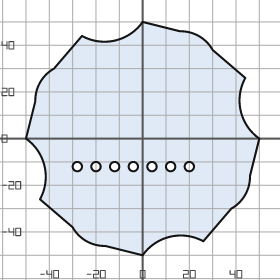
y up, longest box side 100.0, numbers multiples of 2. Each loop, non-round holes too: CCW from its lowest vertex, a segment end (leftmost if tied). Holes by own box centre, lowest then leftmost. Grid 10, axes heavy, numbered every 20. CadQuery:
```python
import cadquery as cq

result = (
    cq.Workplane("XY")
    .moveTo(0.0, -50.0)
    .threePointArc((12.0, -42.0), (26.0, -44.0))
    .lineTo(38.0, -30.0)
    .threePointArc((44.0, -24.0), (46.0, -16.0))
    .lineTo(50.0, 0.0)
    .threePointArc((42.0, 12.0), (44.0, 26.0))
    .lineTo(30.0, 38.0)
    .threePointArc((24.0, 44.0), (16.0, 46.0))
    .lineTo(0.0, 50.0)
    .threePointArc((-12.0, 42.0), (-26.0, 44.0))
    .lineTo(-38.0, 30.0)
    .threePointArc((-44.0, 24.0), (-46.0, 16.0))
    .lineTo(-50.0, 0.0)
    .threePointArc((-42.0, -12.0), (-44.0, -26.0))
    .lineTo(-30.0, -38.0)
    .threePointArc((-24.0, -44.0), (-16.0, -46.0))
    .close()
    .moveTo(-28.0, -12.0)
    .circle(2.0)
    .moveTo(-20.0, -12.0)
    .circle(2.0)
    .moveTo(-12.0, -12.0)
    .circle(2.0)
    .moveTo(-4.0, -12.0)
    .circle(2.0)
    .moveTo(4.0, -12.0)
    .circle(2.0)
    .moveTo(12.0, -12.0)
    .circle(2.0)
    .moveTo(20.0, -12.0)
    .circle(2.0)
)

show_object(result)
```